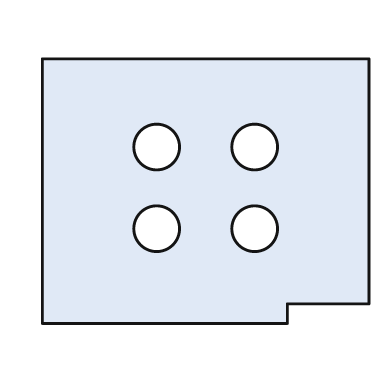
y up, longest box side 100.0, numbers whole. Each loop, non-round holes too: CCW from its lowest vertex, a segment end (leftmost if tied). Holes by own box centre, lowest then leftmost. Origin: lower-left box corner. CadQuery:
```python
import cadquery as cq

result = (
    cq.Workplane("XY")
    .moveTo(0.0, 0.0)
    .lineTo(75.0, 0.0)
    .lineTo(75.0, 6.0)
    .lineTo(100.0, 6.0)
    .lineTo(100.0, 81.0)
    .lineTo(0.0, 81.0)
    .close()
    .moveTo(35.0, 29.0)
    .circle(7.0)
    .moveTo(65.0, 29.0)
    .circle(7.0)
    .moveTo(35.0, 54.0)
    .circle(7.0)
    .moveTo(65.0, 54.0)
    .circle(7.0)
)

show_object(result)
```